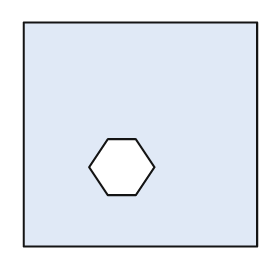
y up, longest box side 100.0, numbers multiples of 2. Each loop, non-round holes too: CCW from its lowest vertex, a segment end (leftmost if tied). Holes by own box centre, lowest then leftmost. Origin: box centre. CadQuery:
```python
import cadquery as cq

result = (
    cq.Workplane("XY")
    .moveTo(-50.0, -48.0)
    .lineTo(50.0, -48.0)
    .lineTo(50.0, 48.0)
    .lineTo(-50.0, 48.0)
    .close()
    .moveTo(-14.0, -26.0)
    .lineTo(-2.0, -26.0)
    .lineTo(6.0, -14.0)
    .lineTo(-2.0, -2.0)
    .lineTo(-14.0, -2.0)
    .lineTo(-22.0, -14.0)
    .close()
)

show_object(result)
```